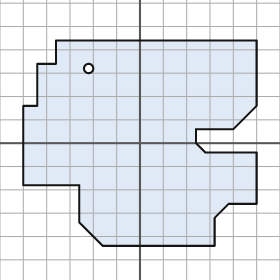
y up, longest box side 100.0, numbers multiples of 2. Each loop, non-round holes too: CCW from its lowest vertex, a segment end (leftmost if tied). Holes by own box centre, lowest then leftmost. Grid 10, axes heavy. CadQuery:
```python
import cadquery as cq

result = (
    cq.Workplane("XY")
    .moveTo(-16.0, -44.0)
    .lineTo(32.0, -44.0)
    .lineTo(32.0, -32.0)
    .lineTo(38.0, -26.0)
    .lineTo(50.0, -26.0)
    .lineTo(50.0, -4.0)
    .lineTo(28.0, -4.0)
    .lineTo(24.0, 0.0)
    .lineTo(24.0, 6.0)
    .lineTo(40.0, 6.0)
    .lineTo(50.0, 16.0)
    .lineTo(50.0, 44.0)
    .lineTo(-36.0, 44.0)
    .lineTo(-36.0, 34.0)
    .lineTo(-44.0, 34.0)
    .lineTo(-44.0, 16.0)
    .lineTo(-50.0, 16.0)
    .lineTo(-50.0, -18.0)
    .lineTo(-26.0, -18.0)
    .lineTo(-26.0, -34.0)
    .close()
    .moveTo(-22.0, 32.0)
    .circle(2.0)
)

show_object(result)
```